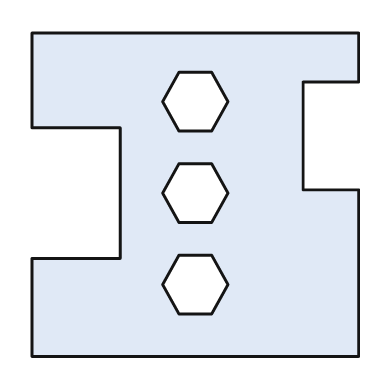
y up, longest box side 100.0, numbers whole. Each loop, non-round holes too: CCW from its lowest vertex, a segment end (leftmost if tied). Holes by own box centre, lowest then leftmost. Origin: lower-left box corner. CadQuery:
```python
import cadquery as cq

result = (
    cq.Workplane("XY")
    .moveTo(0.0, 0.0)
    .lineTo(100.0, 0.0)
    .lineTo(100.0, 51.0)
    .lineTo(83.0, 51.0)
    .lineTo(83.0, 84.0)
    .lineTo(100.0, 84.0)
    .lineTo(100.0, 99.0)
    .lineTo(0.0, 99.0)
    .lineTo(0.0, 70.0)
    .lineTo(27.0, 70.0)
    .lineTo(27.0, 30.0)
    .lineTo(0.0, 30.0)
    .close()
    .moveTo(45.0, 13.0)
    .lineTo(55.0, 13.0)
    .lineTo(60.0, 22.0)
    .lineTo(55.0, 31.0)
    .lineTo(45.0, 31.0)
    .lineTo(40.0, 22.0)
    .close()
    .moveTo(45.0, 41.0)
    .lineTo(55.0, 41.0)
    .lineTo(60.0, 50.0)
    .lineTo(55.0, 59.0)
    .lineTo(45.0, 59.0)
    .lineTo(40.0, 50.0)
    .close()
    .moveTo(45.0, 69.0)
    .lineTo(55.0, 69.0)
    .lineTo(60.0, 78.0)
    .lineTo(55.0, 87.0)
    .lineTo(45.0, 87.0)
    .lineTo(40.0, 78.0)
    .close()
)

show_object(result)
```